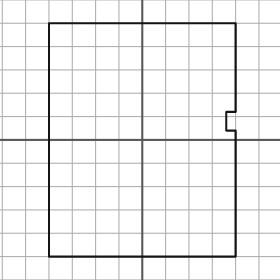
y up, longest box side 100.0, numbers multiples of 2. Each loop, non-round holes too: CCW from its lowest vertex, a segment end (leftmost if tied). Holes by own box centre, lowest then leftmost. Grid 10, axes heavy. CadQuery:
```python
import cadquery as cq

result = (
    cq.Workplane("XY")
    .moveTo(-40.0, -50.0)
    .lineTo(40.0, -50.0)
    .lineTo(40.0, 4.0)
    .lineTo(36.0, 4.0)
    .lineTo(36.0, 12.0)
    .lineTo(40.0, 12.0)
    .lineTo(40.0, 50.0)
    .lineTo(-40.0, 50.0)
    .close()
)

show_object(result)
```